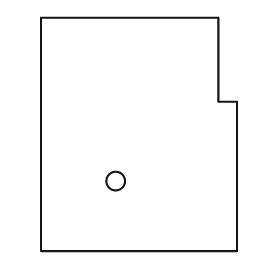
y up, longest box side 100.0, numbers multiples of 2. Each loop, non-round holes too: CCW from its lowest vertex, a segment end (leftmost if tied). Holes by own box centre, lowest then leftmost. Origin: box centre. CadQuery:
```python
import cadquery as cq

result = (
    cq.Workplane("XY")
    .moveTo(-42.0, -50.0)
    .lineTo(42.0, -50.0)
    .lineTo(42.0, 14.0)
    .lineTo(34.0, 14.0)
    .lineTo(34.0, 50.0)
    .lineTo(-42.0, 50.0)
    .close()
    .moveTo(-10.0, -20.0)
    .circle(4.0)
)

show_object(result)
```